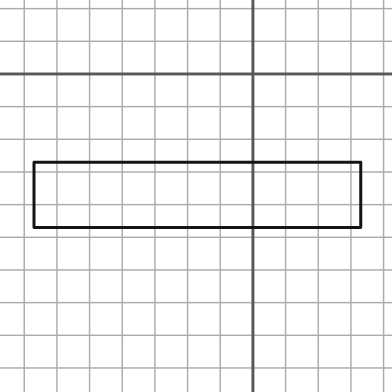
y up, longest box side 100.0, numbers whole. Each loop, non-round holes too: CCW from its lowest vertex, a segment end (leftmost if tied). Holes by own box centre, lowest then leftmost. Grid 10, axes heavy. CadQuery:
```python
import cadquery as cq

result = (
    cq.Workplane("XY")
    .moveTo(-67.0, -47.0)
    .lineTo(33.0, -47.0)
    .lineTo(33.0, -27.0)
    .lineTo(-67.0, -27.0)
    .close()
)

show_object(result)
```